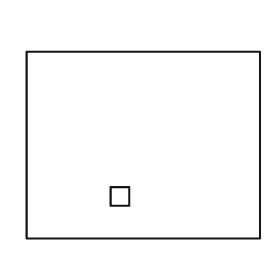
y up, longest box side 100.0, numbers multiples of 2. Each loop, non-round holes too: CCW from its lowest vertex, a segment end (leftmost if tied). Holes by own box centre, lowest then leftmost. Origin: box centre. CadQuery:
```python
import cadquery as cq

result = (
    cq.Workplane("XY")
    .moveTo(-50.0, -40.0)
    .lineTo(50.0, -40.0)
    .lineTo(50.0, 40.0)
    .lineTo(-50.0, 40.0)
    .close()
    .moveTo(-14.0, -26.0)
    .lineTo(-6.0, -26.0)
    .lineTo(-6.0, -18.0)
    .lineTo(-14.0, -18.0)
    .close()
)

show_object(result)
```